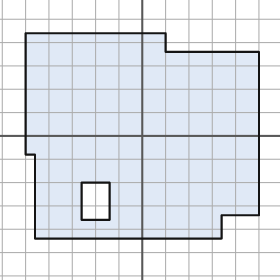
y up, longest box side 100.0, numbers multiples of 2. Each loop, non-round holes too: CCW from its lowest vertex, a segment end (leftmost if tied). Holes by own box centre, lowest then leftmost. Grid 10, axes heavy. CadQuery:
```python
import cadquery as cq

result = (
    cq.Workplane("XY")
    .moveTo(-46.0, -44.0)
    .lineTo(34.0, -44.0)
    .lineTo(34.0, -34.0)
    .lineTo(50.0, -34.0)
    .lineTo(50.0, 36.0)
    .lineTo(10.0, 36.0)
    .lineTo(10.0, 44.0)
    .lineTo(-50.0, 44.0)
    .lineTo(-50.0, -8.0)
    .lineTo(-46.0, -8.0)
    .close()
    .moveTo(-26.0, -36.0)
    .lineTo(-14.0, -36.0)
    .lineTo(-14.0, -20.0)
    .lineTo(-26.0, -20.0)
    .close()
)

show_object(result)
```